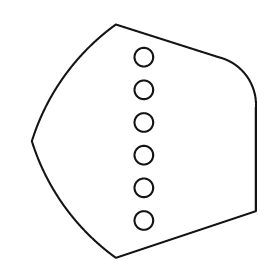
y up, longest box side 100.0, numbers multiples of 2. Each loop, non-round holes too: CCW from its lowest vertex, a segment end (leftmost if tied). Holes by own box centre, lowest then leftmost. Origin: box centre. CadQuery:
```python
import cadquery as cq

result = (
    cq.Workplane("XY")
    .moveTo(-12.0, -50.0)
    .lineTo(48.0, -30.0)
    .lineTo(48.0, 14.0)
    .threePointArc((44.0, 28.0), (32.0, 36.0))
    .lineTo(-12.0, 50.0)
    .threePointArc((-34.0, 28.0), (-48.0, 0.0))
    .threePointArc((-34.0, -28.0), (-12.0, -50.0))
    .close()
    .moveTo(0.0, -34.0)
    .circle(4.0)
    .moveTo(0.0, -20.0)
    .circle(4.0)
    .moveTo(0.0, -6.0)
    .circle(4.0)
    .moveTo(0.0, 8.0)
    .circle(4.0)
    .moveTo(0.0, 22.0)
    .circle(4.0)
    .moveTo(0.0, 36.0)
    .circle(4.0)
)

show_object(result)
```